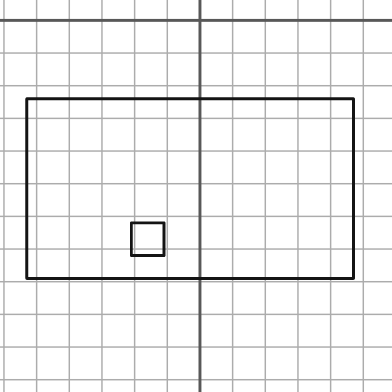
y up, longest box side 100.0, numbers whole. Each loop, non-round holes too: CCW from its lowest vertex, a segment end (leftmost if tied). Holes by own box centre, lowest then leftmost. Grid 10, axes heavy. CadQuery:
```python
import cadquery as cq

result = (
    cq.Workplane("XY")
    .moveTo(-53.0, -79.0)
    .lineTo(47.0, -79.0)
    .lineTo(47.0, -24.0)
    .lineTo(-53.0, -24.0)
    .close()
    .moveTo(-21.0, -72.0)
    .lineTo(-11.0, -72.0)
    .lineTo(-11.0, -62.0)
    .lineTo(-21.0, -62.0)
    .close()
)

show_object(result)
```